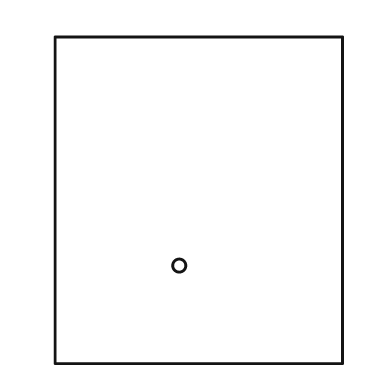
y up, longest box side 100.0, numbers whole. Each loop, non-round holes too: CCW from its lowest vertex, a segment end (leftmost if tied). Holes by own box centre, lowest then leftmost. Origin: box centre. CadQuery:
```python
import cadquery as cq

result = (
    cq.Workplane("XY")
    .moveTo(-44.0, -50.0)
    .lineTo(44.0, -50.0)
    .lineTo(44.0, 50.0)
    .lineTo(-44.0, 50.0)
    .close()
    .moveTo(-6.0, -20.0)
    .circle(2.0)
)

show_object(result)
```